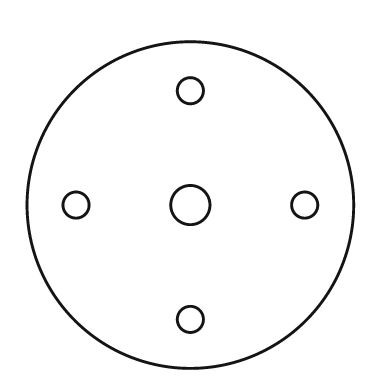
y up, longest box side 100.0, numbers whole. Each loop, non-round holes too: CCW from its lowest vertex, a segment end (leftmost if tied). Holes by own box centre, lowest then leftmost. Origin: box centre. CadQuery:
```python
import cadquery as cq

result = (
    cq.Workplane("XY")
    .moveTo(0.0, 0.0)
    .circle(50.0)
    .moveTo(0.0, -35.0)
    .circle(4.0)
    .moveTo(-35.0, 0.0)
    .circle(4.0)
    .moveTo(0.0, 0.0)
    .circle(6.0)
    .moveTo(35.0, 0.0)
    .circle(4.0)
    .moveTo(0.0, 35.0)
    .circle(4.0)
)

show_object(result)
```